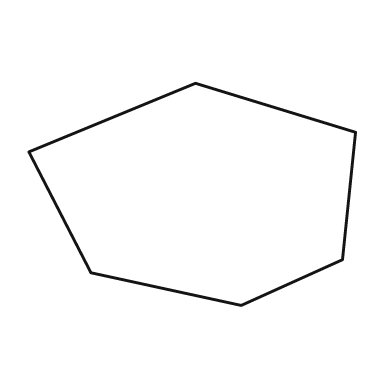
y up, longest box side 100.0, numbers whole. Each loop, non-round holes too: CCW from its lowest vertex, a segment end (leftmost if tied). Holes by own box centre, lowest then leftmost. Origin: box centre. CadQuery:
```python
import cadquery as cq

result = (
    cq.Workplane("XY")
    .moveTo(15.0, -34.0)
    .lineTo(46.0, -20.0)
    .lineTo(50.0, 19.0)
    .lineTo(1.0, 34.0)
    .lineTo(-50.0, 13.0)
    .lineTo(-31.0, -24.0)
    .close()
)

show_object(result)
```